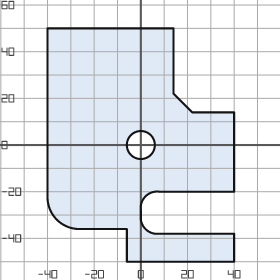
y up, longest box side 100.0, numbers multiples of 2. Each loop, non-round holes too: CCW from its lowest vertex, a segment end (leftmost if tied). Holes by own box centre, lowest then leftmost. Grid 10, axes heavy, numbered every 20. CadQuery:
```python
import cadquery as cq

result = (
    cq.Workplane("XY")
    .moveTo(-6.0, -50.0)
    .lineTo(40.0, -50.0)
    .lineTo(40.0, -38.0)
    .lineTo(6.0, -38.0)
    .threePointArc((2.0, -36.0), (0.0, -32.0))
    .lineTo(0.0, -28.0)
    .threePointArc((2.0, -22.0), (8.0, -20.0))
    .lineTo(40.0, -20.0)
    .lineTo(40.0, 14.0)
    .lineTo(22.0, 14.0)
    .lineTo(14.0, 22.0)
    .lineTo(14.0, 50.0)
    .lineTo(-40.0, 50.0)
    .lineTo(-40.0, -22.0)
    .threePointArc((-36.0, -32.0), (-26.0, -36.0))
    .lineTo(-6.0, -36.0)
    .close()
    .moveTo(0.0, 0.0)
    .circle(6.0)
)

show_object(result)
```